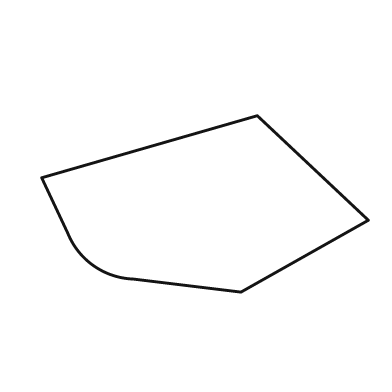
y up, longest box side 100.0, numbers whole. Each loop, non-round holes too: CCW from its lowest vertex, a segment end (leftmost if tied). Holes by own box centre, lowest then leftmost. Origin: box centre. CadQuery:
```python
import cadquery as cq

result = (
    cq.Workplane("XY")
    .moveTo(11.0, -27.0)
    .lineTo(50.0, -5.0)
    .lineTo(16.0, 27.0)
    .lineTo(-50.0, 8.0)
    .lineTo(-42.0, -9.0)
    .threePointArc((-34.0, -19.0), (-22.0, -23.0))
    .close()
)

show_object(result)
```